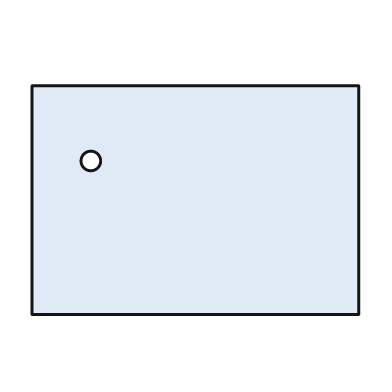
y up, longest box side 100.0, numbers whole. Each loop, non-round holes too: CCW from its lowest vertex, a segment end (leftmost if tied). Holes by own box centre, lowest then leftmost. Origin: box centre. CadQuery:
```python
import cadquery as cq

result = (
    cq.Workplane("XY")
    .moveTo(-50.0, -35.0)
    .lineTo(50.0, -35.0)
    .lineTo(50.0, 35.0)
    .lineTo(-50.0, 35.0)
    .close()
    .moveTo(-32.0, 12.0)
    .circle(3.0)
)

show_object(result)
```